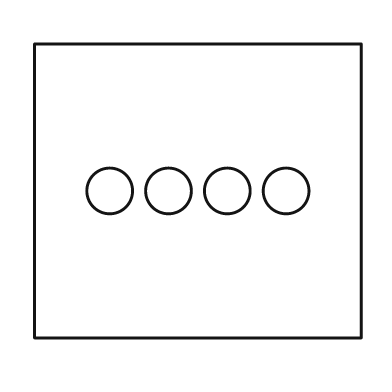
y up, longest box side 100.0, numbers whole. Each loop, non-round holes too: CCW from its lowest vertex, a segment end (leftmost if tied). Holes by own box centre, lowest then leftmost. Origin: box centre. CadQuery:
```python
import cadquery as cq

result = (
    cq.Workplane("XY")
    .moveTo(-50.0, -45.0)
    .lineTo(50.0, -45.0)
    .lineTo(50.0, 45.0)
    .lineTo(-50.0, 45.0)
    .close()
    .moveTo(-27.0, 0.0)
    .circle(7.0)
    .moveTo(-9.0, 0.0)
    .circle(7.0)
    .moveTo(9.0, 0.0)
    .circle(7.0)
    .moveTo(27.0, 0.0)
    .circle(7.0)
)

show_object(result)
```